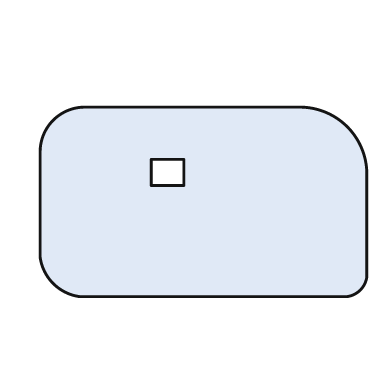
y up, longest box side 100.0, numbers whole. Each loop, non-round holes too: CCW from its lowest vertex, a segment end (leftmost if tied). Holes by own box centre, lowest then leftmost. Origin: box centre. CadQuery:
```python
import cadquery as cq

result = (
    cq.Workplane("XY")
    .moveTo(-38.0, -29.0)
    .lineTo(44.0, -29.0)
    .threePointArc((48.0, -27.0), (50.0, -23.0))
    .lineTo(50.0, 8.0)
    .threePointArc((44.0, 23.0), (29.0, 29.0))
    .lineTo(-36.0, 29.0)
    .threePointArc((-46.0, 25.0), (-50.0, 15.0))
    .lineTo(-50.0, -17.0)
    .threePointArc((-46.0, -25.0), (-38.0, -29.0))
    .close()
    .moveTo(-16.0, 5.0)
    .lineTo(-6.0, 5.0)
    .lineTo(-6.0, 13.0)
    .lineTo(-16.0, 13.0)
    .close()
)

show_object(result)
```